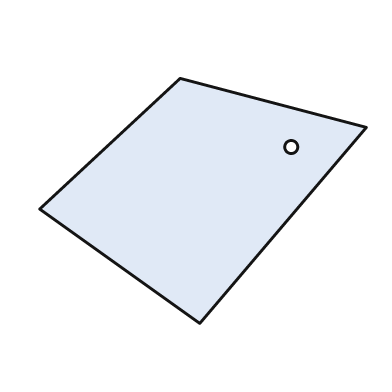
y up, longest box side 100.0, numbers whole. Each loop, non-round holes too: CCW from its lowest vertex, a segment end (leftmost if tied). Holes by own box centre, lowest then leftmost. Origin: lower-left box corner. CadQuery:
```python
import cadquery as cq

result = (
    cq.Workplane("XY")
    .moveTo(49.0, 0.0)
    .lineTo(100.0, 60.0)
    .lineTo(43.0, 75.0)
    .lineTo(0.0, 35.0)
    .close()
    .moveTo(77.0, 54.0)
    .circle(2.0)
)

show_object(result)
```